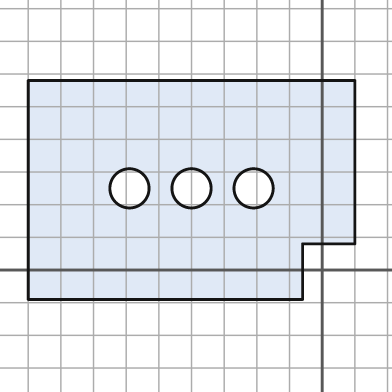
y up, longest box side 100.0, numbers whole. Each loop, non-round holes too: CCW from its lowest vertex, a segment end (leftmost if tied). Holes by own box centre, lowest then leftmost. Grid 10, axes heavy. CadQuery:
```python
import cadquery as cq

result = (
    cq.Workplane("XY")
    .moveTo(-90.0, -9.0)
    .lineTo(-6.0, -9.0)
    .lineTo(-6.0, 8.0)
    .lineTo(10.0, 8.0)
    .lineTo(10.0, 58.0)
    .lineTo(-90.0, 58.0)
    .close()
    .moveTo(-59.0, 25.0)
    .circle(6.0)
    .moveTo(-40.0, 25.0)
    .circle(6.0)
    .moveTo(-21.0, 25.0)
    .circle(6.0)
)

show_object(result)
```